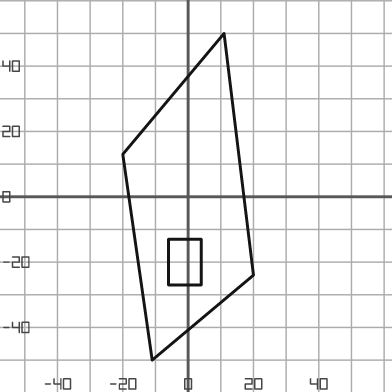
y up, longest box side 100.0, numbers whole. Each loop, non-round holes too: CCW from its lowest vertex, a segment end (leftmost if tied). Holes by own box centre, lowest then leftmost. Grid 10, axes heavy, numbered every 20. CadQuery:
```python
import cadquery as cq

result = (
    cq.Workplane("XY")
    .moveTo(-11.0, -50.0)
    .lineTo(20.0, -24.0)
    .lineTo(11.0, 50.0)
    .lineTo(-20.0, 13.0)
    .close()
    .moveTo(-6.0, -27.0)
    .lineTo(4.0, -27.0)
    .lineTo(4.0, -13.0)
    .lineTo(-6.0, -13.0)
    .close()
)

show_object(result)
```